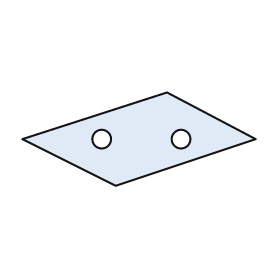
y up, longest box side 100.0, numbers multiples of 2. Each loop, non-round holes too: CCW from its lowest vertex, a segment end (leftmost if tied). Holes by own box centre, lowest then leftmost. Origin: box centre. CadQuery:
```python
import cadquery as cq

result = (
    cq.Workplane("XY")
    .moveTo(-10.0, -20.0)
    .lineTo(50.0, 0.0)
    .lineTo(12.0, 20.0)
    .lineTo(-50.0, 0.0)
    .close()
    .moveTo(-16.0, 0.0)
    .circle(4.0)
    .moveTo(18.0, 0.0)
    .circle(4.0)
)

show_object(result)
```